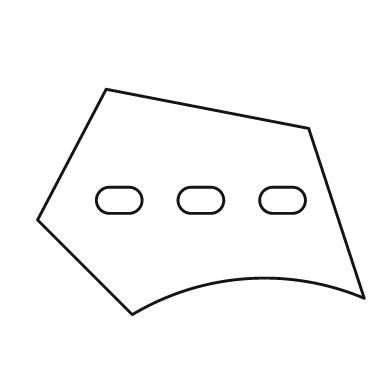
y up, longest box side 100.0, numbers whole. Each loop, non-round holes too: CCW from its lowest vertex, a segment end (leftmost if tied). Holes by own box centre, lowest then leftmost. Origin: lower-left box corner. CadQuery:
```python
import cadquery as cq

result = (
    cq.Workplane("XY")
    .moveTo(29.0, 0.0)
    .threePointArc((64.0, 11.0), (100.0, 5.0))
    .lineTo(83.0, 57.0)
    .lineTo(21.0, 69.0)
    .lineTo(0.0, 29.0)
    .close()
    .moveTo(22.0, 31.0)
    .lineTo(28.0, 31.0)
    .threePointArc((32.0, 35.0), (28.0, 39.0))
    .lineTo(22.0, 39.0)
    .threePointArc((18.0, 35.0), (22.0, 31.0))
    .close()
    .moveTo(47.0, 31.0)
    .lineTo(53.0, 31.0)
    .threePointArc((57.0, 35.0), (53.0, 39.0))
    .lineTo(47.0, 39.0)
    .threePointArc((43.0, 35.0), (47.0, 31.0))
    .close()
    .moveTo(72.0, 31.0)
    .lineTo(78.0, 31.0)
    .threePointArc((82.0, 35.0), (78.0, 39.0))
    .lineTo(72.0, 39.0)
    .threePointArc((68.0, 35.0), (72.0, 31.0))
    .close()
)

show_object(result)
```